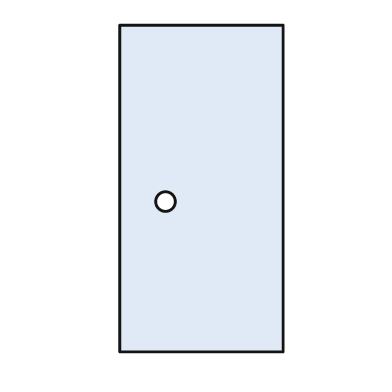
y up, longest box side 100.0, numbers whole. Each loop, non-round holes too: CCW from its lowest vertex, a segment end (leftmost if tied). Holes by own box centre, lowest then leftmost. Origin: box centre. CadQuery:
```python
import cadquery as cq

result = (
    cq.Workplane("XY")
    .moveTo(-25.0, -50.0)
    .lineTo(25.0, -50.0)
    .lineTo(25.0, 50.0)
    .lineTo(-25.0, 50.0)
    .close()
    .moveTo(-11.0, -4.0)
    .circle(3.0)
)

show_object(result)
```